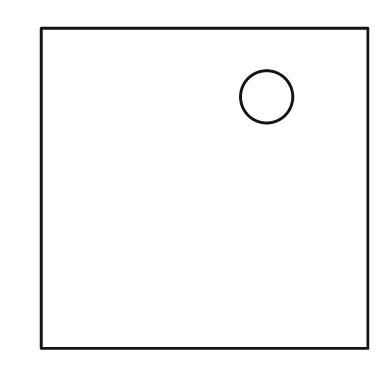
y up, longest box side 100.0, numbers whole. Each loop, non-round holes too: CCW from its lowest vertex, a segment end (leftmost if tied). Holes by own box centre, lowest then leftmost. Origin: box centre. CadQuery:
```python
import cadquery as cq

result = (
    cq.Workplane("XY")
    .moveTo(-50.0, -49.0)
    .lineTo(50.0, -49.0)
    .lineTo(50.0, 49.0)
    .lineTo(-50.0, 49.0)
    .close()
    .moveTo(19.0, 28.0)
    .circle(8.0)
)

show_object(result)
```